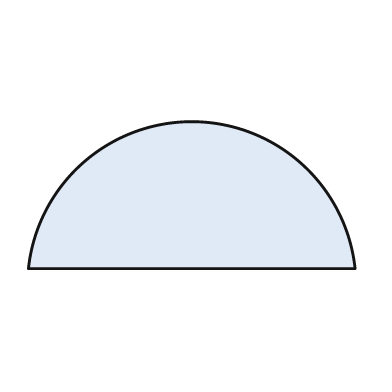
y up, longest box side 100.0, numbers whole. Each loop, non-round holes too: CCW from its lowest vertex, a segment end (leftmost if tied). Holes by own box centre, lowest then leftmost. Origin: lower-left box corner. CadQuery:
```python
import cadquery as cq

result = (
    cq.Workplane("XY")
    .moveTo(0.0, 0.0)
    .lineTo(100.0, 0.0)
    .threePointArc((50.0, 45.0), (0.0, 0.0))
    .close()
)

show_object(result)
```